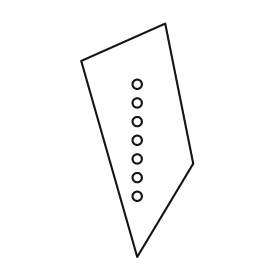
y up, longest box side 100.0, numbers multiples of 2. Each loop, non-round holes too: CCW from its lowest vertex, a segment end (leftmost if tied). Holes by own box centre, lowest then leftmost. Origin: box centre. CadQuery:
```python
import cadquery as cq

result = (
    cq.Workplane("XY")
    .moveTo(0.0, -50.0)
    .lineTo(24.0, -10.0)
    .lineTo(12.0, 50.0)
    .lineTo(-24.0, 34.0)
    .close()
    .moveTo(0.0, -24.0)
    .circle(2.0)
    .moveTo(0.0, -16.0)
    .circle(2.0)
    .moveTo(0.0, -8.0)
    .circle(2.0)
    .moveTo(0.0, 0.0)
    .circle(2.0)
    .moveTo(0.0, 8.0)
    .circle(2.0)
    .moveTo(0.0, 16.0)
    .circle(2.0)
    .moveTo(0.0, 24.0)
    .circle(2.0)
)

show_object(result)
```